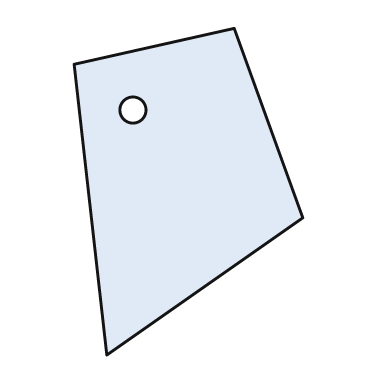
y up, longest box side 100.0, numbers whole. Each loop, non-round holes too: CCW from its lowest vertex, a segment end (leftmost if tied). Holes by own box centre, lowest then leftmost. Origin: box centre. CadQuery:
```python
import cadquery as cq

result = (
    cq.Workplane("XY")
    .moveTo(-25.0, -50.0)
    .lineTo(35.0, -8.0)
    .lineTo(14.0, 50.0)
    .lineTo(-35.0, 39.0)
    .close()
    .moveTo(-17.0, 25.0)
    .circle(4.0)
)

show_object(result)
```